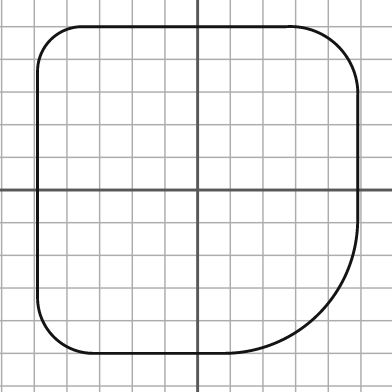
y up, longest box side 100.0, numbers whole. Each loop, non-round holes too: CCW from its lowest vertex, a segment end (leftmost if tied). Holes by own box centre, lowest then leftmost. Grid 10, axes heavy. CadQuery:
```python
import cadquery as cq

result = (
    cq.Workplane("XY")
    .moveTo(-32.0, -50.0)
    .lineTo(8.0, -50.0)
    .threePointArc((37.0, -38.0), (49.0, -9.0))
    .lineTo(49.0, 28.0)
    .threePointArc((43.0, 44.0), (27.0, 50.0))
    .lineTo(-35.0, 50.0)
    .threePointArc((-45.0, 46.0), (-49.0, 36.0))
    .lineTo(-49.0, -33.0)
    .threePointArc((-44.0, -45.0), (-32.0, -50.0))
    .close()
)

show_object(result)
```